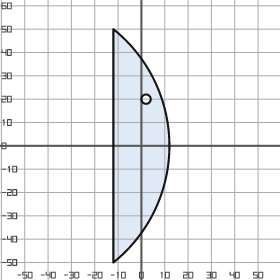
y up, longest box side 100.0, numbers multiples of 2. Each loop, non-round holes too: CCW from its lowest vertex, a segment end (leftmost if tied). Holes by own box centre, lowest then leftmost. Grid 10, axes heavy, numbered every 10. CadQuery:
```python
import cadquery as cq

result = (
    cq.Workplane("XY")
    .moveTo(-12.0, -50.0)
    .threePointArc((12.0, 0.0), (-12.0, 50.0))
    .close()
    .moveTo(2.0, 20.0)
    .circle(2.0)
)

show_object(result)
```